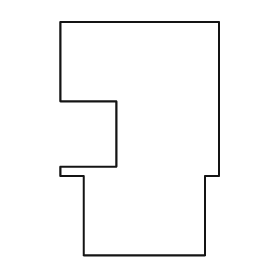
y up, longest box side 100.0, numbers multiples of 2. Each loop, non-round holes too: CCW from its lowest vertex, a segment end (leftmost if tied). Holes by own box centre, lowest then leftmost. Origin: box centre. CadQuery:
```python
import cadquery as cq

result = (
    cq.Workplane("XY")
    .moveTo(-24.0, -50.0)
    .lineTo(28.0, -50.0)
    .lineTo(28.0, -16.0)
    .lineTo(34.0, -16.0)
    .lineTo(34.0, 50.0)
    .lineTo(-34.0, 50.0)
    .lineTo(-34.0, 16.0)
    .lineTo(-10.0, 16.0)
    .lineTo(-10.0, -12.0)
    .lineTo(-34.0, -12.0)
    .lineTo(-34.0, -16.0)
    .lineTo(-24.0, -16.0)
    .close()
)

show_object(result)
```